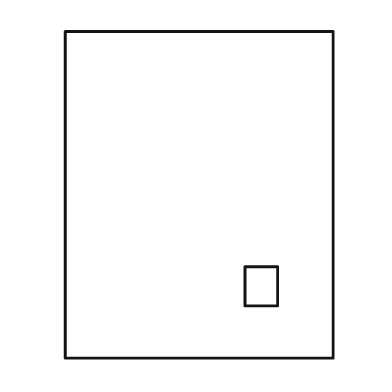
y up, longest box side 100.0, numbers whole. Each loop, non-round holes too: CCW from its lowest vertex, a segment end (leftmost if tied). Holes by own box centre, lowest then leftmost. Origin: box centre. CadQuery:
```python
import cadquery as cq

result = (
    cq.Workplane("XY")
    .moveTo(-41.0, -50.0)
    .lineTo(41.0, -50.0)
    .lineTo(41.0, 50.0)
    .lineTo(-41.0, 50.0)
    .close()
    .moveTo(14.0, -34.0)
    .lineTo(24.0, -34.0)
    .lineTo(24.0, -22.0)
    .lineTo(14.0, -22.0)
    .close()
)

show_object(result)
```